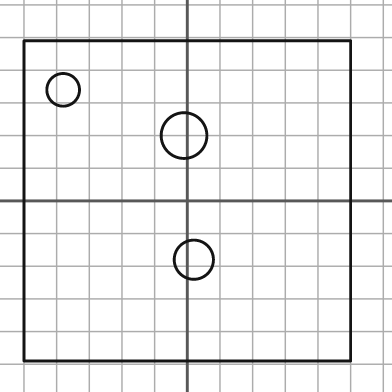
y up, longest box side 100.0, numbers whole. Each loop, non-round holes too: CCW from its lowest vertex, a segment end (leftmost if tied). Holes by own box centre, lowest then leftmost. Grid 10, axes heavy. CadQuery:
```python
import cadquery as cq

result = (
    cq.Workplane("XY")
    .moveTo(-50.0, -49.0)
    .lineTo(50.0, -49.0)
    .lineTo(50.0, 49.0)
    .lineTo(-50.0, 49.0)
    .close()
    .moveTo(2.0, -18.0)
    .circle(6.0)
    .moveTo(-1.0, 20.0)
    .circle(7.0)
    .moveTo(-38.0, 34.0)
    .circle(5.0)
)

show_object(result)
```